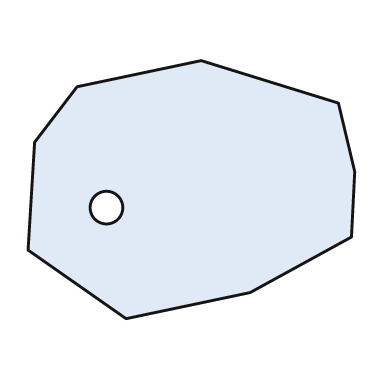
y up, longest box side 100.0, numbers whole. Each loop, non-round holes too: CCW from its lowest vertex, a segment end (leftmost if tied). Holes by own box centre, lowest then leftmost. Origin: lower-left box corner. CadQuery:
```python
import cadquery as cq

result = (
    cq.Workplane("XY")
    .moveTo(30.0, 0.0)
    .lineTo(68.0, 8.0)
    .lineTo(99.0, 25.0)
    .lineTo(100.0, 45.0)
    .lineTo(95.0, 66.0)
    .lineTo(53.0, 79.0)
    .lineTo(15.0, 71.0)
    .lineTo(2.0, 54.0)
    .lineTo(0.0, 21.0)
    .close()
    .moveTo(24.0, 34.0)
    .circle(5.0)
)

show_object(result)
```